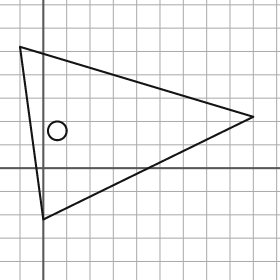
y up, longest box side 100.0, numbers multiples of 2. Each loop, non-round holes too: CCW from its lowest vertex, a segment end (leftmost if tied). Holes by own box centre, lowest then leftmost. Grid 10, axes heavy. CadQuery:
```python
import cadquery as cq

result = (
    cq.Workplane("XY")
    .moveTo(0.0, -22.0)
    .lineTo(90.0, 22.0)
    .lineTo(-10.0, 52.0)
    .close()
    .moveTo(6.0, 16.0)
    .circle(4.0)
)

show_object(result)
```